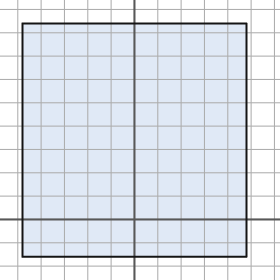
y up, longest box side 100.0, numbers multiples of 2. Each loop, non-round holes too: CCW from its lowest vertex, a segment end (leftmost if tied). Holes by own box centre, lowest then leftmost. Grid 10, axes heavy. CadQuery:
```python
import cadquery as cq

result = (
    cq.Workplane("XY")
    .moveTo(-48.0, -16.0)
    .lineTo(48.0, -16.0)
    .lineTo(48.0, 84.0)
    .lineTo(-48.0, 84.0)
    .close()
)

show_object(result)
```